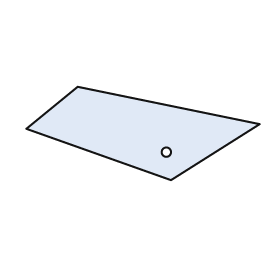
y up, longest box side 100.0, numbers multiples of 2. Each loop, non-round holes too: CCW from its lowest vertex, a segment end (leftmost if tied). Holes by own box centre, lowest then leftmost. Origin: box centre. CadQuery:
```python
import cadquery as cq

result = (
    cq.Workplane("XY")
    .moveTo(12.0, -20.0)
    .lineTo(50.0, 4.0)
    .lineTo(-28.0, 20.0)
    .lineTo(-50.0, 2.0)
    .close()
    .moveTo(10.0, -8.0)
    .circle(2.0)
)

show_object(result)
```